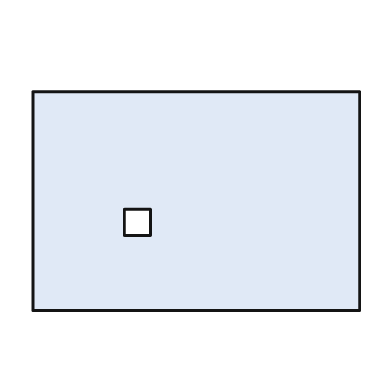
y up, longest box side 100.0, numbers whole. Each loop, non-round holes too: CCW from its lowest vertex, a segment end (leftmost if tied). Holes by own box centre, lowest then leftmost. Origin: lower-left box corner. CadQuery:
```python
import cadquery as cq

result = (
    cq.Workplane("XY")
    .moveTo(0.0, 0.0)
    .lineTo(100.0, 0.0)
    .lineTo(100.0, 67.0)
    .lineTo(0.0, 67.0)
    .close()
    .moveTo(28.0, 23.0)
    .lineTo(36.0, 23.0)
    .lineTo(36.0, 31.0)
    .lineTo(28.0, 31.0)
    .close()
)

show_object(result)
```